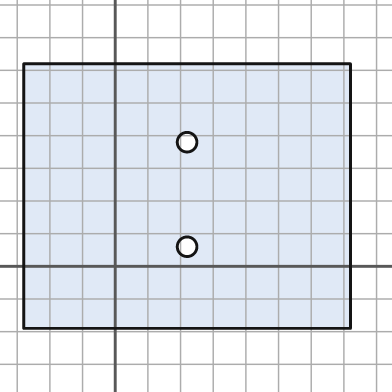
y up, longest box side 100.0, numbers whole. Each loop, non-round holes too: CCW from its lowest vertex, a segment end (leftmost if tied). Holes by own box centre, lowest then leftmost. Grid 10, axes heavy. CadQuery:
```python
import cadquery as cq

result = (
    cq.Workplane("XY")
    .moveTo(-28.0, -19.0)
    .lineTo(72.0, -19.0)
    .lineTo(72.0, 62.0)
    .lineTo(-28.0, 62.0)
    .close()
    .moveTo(22.0, 6.0)
    .circle(3.0)
    .moveTo(22.0, 38.0)
    .circle(3.0)
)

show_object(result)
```